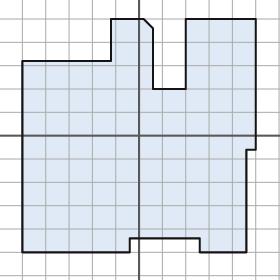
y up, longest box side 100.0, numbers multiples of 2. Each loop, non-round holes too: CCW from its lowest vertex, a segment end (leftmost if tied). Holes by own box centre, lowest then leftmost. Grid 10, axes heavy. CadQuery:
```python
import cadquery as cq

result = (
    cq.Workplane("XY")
    .moveTo(-50.0, -50.0)
    .lineTo(-4.0, -50.0)
    .lineTo(-4.0, -44.0)
    .lineTo(26.0, -44.0)
    .lineTo(26.0, -50.0)
    .lineTo(46.0, -50.0)
    .lineTo(46.0, -6.0)
    .lineTo(50.0, -6.0)
    .lineTo(50.0, 50.0)
    .lineTo(20.0, 50.0)
    .lineTo(20.0, 20.0)
    .lineTo(6.0, 20.0)
    .lineTo(6.0, 46.0)
    .lineTo(2.0, 50.0)
    .lineTo(-12.0, 50.0)
    .lineTo(-12.0, 32.0)
    .lineTo(-50.0, 32.0)
    .close()
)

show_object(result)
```